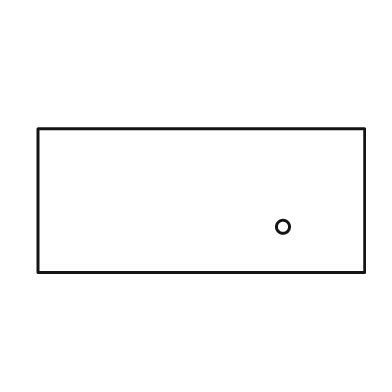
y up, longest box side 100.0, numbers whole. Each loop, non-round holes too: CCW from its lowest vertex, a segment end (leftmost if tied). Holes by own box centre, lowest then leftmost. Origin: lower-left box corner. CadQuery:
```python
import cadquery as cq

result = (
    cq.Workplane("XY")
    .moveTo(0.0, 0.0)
    .lineTo(100.0, 0.0)
    .lineTo(100.0, 44.0)
    .lineTo(0.0, 44.0)
    .close()
    .moveTo(75.0, 14.0)
    .circle(2.0)
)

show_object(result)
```